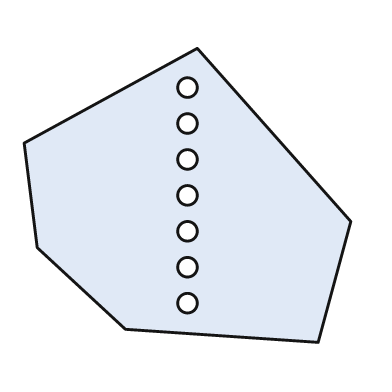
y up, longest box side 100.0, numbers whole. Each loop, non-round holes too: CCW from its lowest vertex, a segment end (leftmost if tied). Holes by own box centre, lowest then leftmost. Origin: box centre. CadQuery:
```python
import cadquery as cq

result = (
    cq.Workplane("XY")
    .moveTo(40.0, -45.0)
    .lineTo(50.0, -8.0)
    .lineTo(3.0, 45.0)
    .lineTo(-50.0, 16.0)
    .lineTo(-46.0, -16.0)
    .lineTo(-19.0, -41.0)
    .close()
    .moveTo(0.0, -33.0)
    .circle(3.0)
    .moveTo(0.0, -22.0)
    .circle(3.0)
    .moveTo(0.0, -11.0)
    .circle(3.0)
    .moveTo(0.0, 0.0)
    .circle(3.0)
    .moveTo(0.0, 11.0)
    .circle(3.0)
    .moveTo(0.0, 22.0)
    .circle(3.0)
    .moveTo(0.0, 33.0)
    .circle(3.0)
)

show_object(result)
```